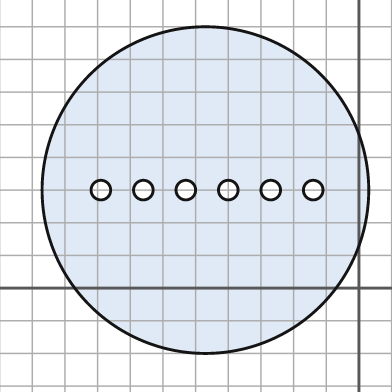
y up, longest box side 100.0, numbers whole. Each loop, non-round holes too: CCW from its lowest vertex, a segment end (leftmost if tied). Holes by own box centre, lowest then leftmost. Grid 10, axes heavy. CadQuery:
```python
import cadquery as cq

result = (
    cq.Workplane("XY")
    .moveTo(-47.0, 30.0)
    .circle(50.0)
    .moveTo(-79.0, 30.0)
    .circle(3.0)
    .moveTo(-66.0, 30.0)
    .circle(3.0)
    .moveTo(-53.0, 30.0)
    .circle(3.0)
    .moveTo(-40.0, 30.0)
    .circle(3.0)
    .moveTo(-27.0, 30.0)
    .circle(3.0)
    .moveTo(-14.0, 30.0)
    .circle(3.0)
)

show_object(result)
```